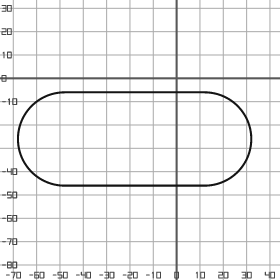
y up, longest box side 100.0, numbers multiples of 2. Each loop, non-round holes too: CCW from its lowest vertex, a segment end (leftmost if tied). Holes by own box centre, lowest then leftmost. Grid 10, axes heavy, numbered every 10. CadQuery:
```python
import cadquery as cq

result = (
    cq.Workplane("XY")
    .moveTo(-48.0, -46.0)
    .lineTo(12.0, -46.0)
    .threePointArc((32.0, -26.0), (12.0, -6.0))
    .lineTo(-48.0, -6.0)
    .threePointArc((-68.0, -26.0), (-48.0, -46.0))
    .close()
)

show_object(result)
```